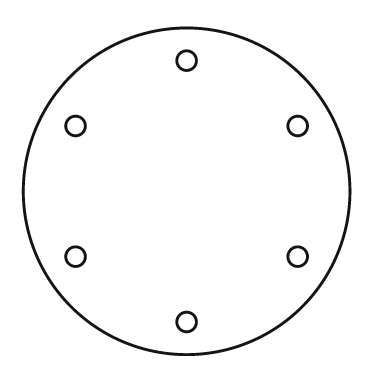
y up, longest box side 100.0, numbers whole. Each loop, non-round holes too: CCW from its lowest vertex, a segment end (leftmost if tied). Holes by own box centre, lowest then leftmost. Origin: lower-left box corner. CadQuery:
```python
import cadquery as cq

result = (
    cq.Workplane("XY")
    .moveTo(50.0, 50.0)
    .circle(50.0)
    .moveTo(50.0, 10.0)
    .circle(3.0)
    .moveTo(16.0, 30.0)
    .circle(3.0)
    .moveTo(84.0, 30.0)
    .circle(3.0)
    .moveTo(16.0, 70.0)
    .circle(3.0)
    .moveTo(84.0, 70.0)
    .circle(3.0)
    .moveTo(50.0, 90.0)
    .circle(3.0)
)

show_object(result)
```